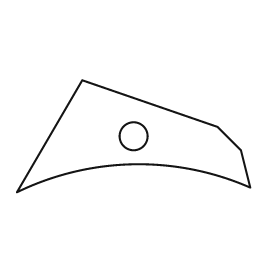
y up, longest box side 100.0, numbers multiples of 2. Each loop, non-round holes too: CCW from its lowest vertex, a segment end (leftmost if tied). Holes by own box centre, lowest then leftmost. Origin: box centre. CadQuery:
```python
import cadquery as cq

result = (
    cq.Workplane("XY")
    .moveTo(-50.0, -24.0)
    .threePointArc((0.0, -12.0), (50.0, -22.0))
    .lineTo(46.0, -6.0)
    .lineTo(36.0, 4.0)
    .lineTo(-22.0, 24.0)
    .close()
    .moveTo(0.0, 0.0)
    .circle(6.0)
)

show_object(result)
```